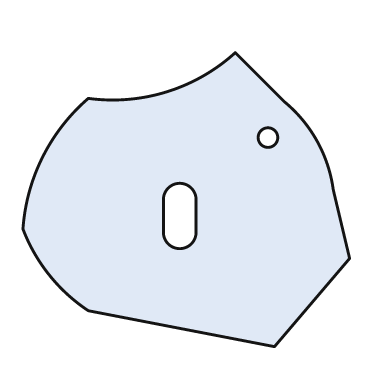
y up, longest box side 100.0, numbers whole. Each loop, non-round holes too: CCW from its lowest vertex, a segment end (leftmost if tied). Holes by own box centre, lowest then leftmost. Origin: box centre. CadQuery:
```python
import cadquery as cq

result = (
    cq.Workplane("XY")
    .moveTo(27.0, -45.0)
    .lineTo(50.0, -18.0)
    .lineTo(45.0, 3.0)
    .threePointArc((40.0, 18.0), (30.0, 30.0))
    .lineTo(15.0, 45.0)
    .threePointArc((-6.0, 33.0), (-30.0, 31.0))
    .threePointArc((-44.0, 13.0), (-50.0, -9.0))
    .threePointArc((-42.0, -23.0), (-30.0, -34.0))
    .close()
    .moveTo(-7.0, -10.0)
    .threePointArc((-2.0, -15.0), (3.0, -10.0))
    .lineTo(3.0, 0.0)
    .threePointArc((-2.0, 5.0), (-7.0, 0.0))
    .close()
    .moveTo(25.0, 19.0)
    .circle(3.0)
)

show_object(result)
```